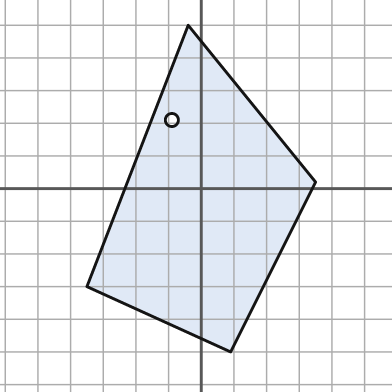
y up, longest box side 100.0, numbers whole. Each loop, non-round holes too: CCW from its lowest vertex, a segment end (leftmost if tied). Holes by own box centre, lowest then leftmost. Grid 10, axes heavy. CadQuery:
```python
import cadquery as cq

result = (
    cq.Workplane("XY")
    .moveTo(9.0, -50.0)
    .lineTo(35.0, 2.0)
    .lineTo(-4.0, 50.0)
    .lineTo(-35.0, -30.0)
    .close()
    .moveTo(-9.0, 21.0)
    .circle(2.0)
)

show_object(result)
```